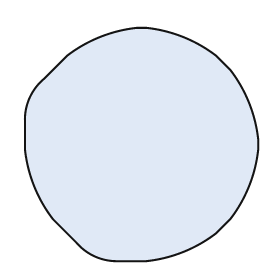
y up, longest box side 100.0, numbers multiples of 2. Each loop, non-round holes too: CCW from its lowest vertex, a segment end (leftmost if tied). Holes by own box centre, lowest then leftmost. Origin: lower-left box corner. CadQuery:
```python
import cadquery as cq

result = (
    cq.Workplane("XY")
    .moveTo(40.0, 0.0)
    .lineTo(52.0, 0.0)
    .threePointArc((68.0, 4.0), (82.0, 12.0))
    .lineTo(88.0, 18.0)
    .threePointArc((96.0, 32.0), (100.0, 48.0))
    .lineTo(100.0, 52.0)
    .threePointArc((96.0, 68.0), (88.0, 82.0))
    .lineTo(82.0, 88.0)
    .threePointArc((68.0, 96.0), (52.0, 100.0))
    .lineTo(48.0, 100.0)
    .threePointArc((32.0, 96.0), (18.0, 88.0))
    .lineTo(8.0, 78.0)
    .threePointArc((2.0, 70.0), (0.0, 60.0))
    .lineTo(0.0, 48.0)
    .threePointArc((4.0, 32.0), (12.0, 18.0))
    .lineTo(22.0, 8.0)
    .threePointArc((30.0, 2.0), (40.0, 0.0))
    .close()
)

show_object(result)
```